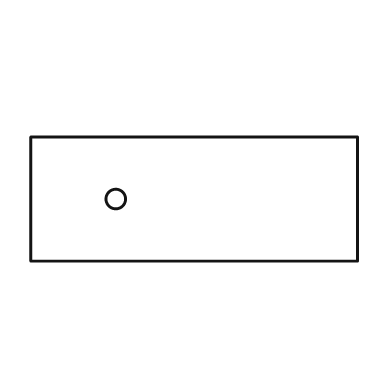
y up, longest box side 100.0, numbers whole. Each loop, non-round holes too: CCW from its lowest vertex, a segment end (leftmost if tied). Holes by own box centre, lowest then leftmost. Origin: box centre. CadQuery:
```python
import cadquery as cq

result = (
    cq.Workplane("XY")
    .moveTo(-50.0, -19.0)
    .lineTo(50.0, -19.0)
    .lineTo(50.0, 19.0)
    .lineTo(-50.0, 19.0)
    .close()
    .moveTo(-24.0, 0.0)
    .circle(3.0)
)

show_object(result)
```